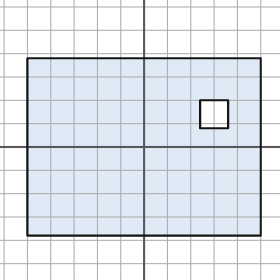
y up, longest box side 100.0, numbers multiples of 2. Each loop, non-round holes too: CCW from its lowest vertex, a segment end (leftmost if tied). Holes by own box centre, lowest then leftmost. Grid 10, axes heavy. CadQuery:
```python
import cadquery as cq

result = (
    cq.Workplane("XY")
    .moveTo(-50.0, -38.0)
    .lineTo(50.0, -38.0)
    .lineTo(50.0, 38.0)
    .lineTo(-50.0, 38.0)
    .close()
    .moveTo(24.0, 8.0)
    .lineTo(36.0, 8.0)
    .lineTo(36.0, 20.0)
    .lineTo(24.0, 20.0)
    .close()
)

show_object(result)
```